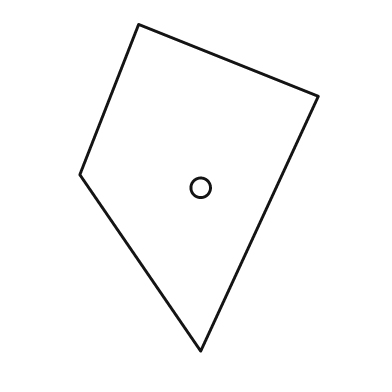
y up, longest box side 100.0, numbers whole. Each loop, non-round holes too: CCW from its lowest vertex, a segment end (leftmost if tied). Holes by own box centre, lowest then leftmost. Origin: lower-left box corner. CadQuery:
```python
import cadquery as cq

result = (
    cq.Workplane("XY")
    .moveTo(37.0, 0.0)
    .lineTo(73.0, 78.0)
    .lineTo(18.0, 100.0)
    .lineTo(0.0, 54.0)
    .close()
    .moveTo(37.0, 50.0)
    .circle(3.0)
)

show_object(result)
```